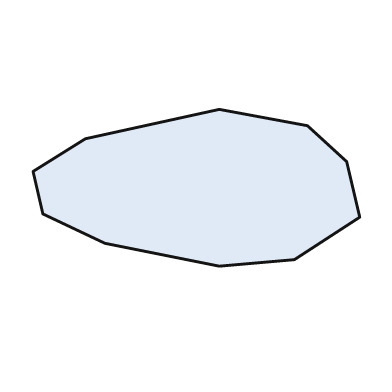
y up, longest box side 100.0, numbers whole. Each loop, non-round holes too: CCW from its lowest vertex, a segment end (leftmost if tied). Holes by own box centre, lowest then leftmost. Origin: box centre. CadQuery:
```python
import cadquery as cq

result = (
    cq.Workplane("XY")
    .moveTo(7.0, -24.0)
    .lineTo(30.0, -22.0)
    .lineTo(50.0, -9.0)
    .lineTo(46.0, 8.0)
    .lineTo(34.0, 19.0)
    .lineTo(7.0, 24.0)
    .lineTo(-34.0, 15.0)
    .lineTo(-50.0, 5.0)
    .lineTo(-47.0, -8.0)
    .lineTo(-28.0, -17.0)
    .close()
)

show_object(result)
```